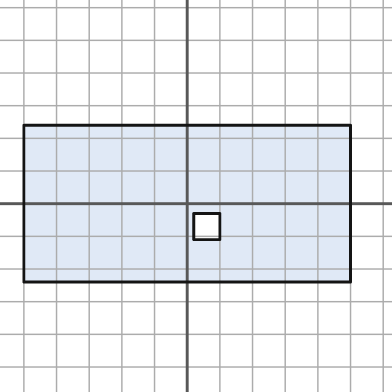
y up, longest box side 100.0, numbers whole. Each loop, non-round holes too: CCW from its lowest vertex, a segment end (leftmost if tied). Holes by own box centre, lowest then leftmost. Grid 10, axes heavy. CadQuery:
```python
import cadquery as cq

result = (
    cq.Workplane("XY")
    .moveTo(-50.0, -24.0)
    .lineTo(50.0, -24.0)
    .lineTo(50.0, 24.0)
    .lineTo(-50.0, 24.0)
    .close()
    .moveTo(2.0, -11.0)
    .lineTo(10.0, -11.0)
    .lineTo(10.0, -3.0)
    .lineTo(2.0, -3.0)
    .close()
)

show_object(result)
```